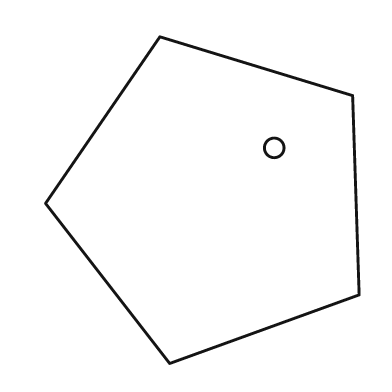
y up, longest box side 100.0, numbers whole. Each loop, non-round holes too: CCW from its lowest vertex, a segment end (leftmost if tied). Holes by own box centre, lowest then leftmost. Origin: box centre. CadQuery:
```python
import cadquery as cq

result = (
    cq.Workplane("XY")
    .moveTo(-10.0, -50.0)
    .lineTo(48.0, -29.0)
    .lineTo(46.0, 32.0)
    .lineTo(-13.0, 50.0)
    .lineTo(-48.0, -1.0)
    .close()
    .moveTo(22.0, 16.0)
    .circle(3.0)
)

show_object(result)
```